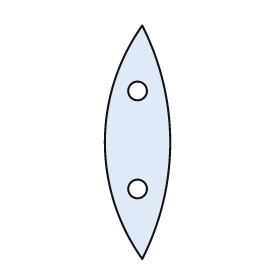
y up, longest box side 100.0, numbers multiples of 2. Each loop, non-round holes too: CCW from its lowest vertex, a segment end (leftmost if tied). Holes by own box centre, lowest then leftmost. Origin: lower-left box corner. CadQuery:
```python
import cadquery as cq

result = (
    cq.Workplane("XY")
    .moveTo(16.0, 0.0)
    .threePointArc((28.0, 50.0), (16.0, 100.0))
    .threePointArc((0.0, 50.0), (16.0, 0.0))
    .close()
    .moveTo(14.0, 30.0)
    .circle(4.0)
    .moveTo(14.0, 72.0)
    .circle(4.0)
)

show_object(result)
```